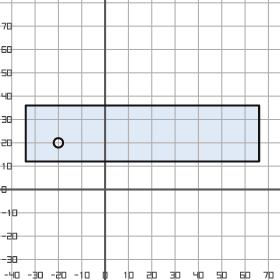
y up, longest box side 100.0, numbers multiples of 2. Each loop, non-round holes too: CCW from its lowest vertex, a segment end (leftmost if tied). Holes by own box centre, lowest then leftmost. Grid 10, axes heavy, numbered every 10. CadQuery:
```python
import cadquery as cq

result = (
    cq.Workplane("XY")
    .moveTo(-34.0, 12.0)
    .lineTo(66.0, 12.0)
    .lineTo(66.0, 36.0)
    .lineTo(-34.0, 36.0)
    .close()
    .moveTo(-20.0, 20.0)
    .circle(2.0)
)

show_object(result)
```